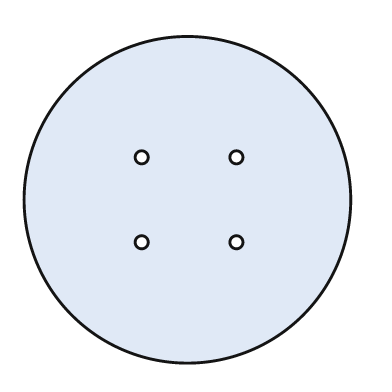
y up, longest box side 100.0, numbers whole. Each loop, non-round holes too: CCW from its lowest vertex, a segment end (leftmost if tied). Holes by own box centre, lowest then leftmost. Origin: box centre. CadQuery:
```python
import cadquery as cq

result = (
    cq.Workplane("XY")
    .moveTo(0.0, 0.0)
    .circle(50.0)
    .moveTo(-14.0, -13.0)
    .circle(2.0)
    .moveTo(15.0, -13.0)
    .circle(2.0)
    .moveTo(-14.0, 13.0)
    .circle(2.0)
    .moveTo(15.0, 13.0)
    .circle(2.0)
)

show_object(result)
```